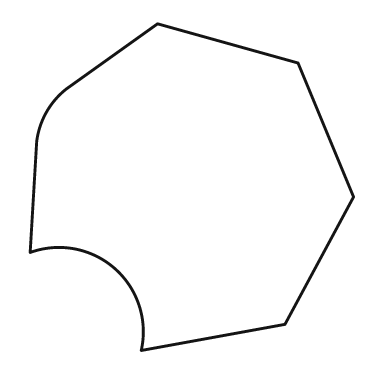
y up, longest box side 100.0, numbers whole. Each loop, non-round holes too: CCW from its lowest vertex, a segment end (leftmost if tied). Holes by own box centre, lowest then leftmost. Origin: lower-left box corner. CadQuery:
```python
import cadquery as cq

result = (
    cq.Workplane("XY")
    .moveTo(34.0, 0.0)
    .lineTo(78.0, 8.0)
    .lineTo(99.0, 47.0)
    .lineTo(82.0, 88.0)
    .lineTo(39.0, 100.0)
    .lineTo(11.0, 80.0)
    .threePointArc((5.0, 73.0), (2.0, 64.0))
    .lineTo(0.0, 30.0)
    .threePointArc((26.0, 25.0), (34.0, 0.0))
    .close()
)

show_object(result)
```